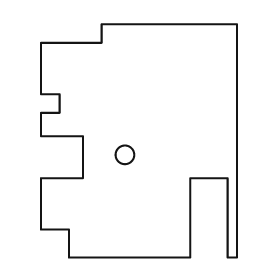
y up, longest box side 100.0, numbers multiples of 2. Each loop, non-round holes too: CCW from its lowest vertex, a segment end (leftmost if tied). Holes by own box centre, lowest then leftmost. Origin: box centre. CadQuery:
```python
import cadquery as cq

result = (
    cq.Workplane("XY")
    .moveTo(-30.0, -50.0)
    .lineTo(22.0, -50.0)
    .lineTo(22.0, -16.0)
    .lineTo(38.0, -16.0)
    .lineTo(38.0, -50.0)
    .lineTo(42.0, -50.0)
    .lineTo(42.0, 50.0)
    .lineTo(-16.0, 50.0)
    .lineTo(-16.0, 42.0)
    .lineTo(-42.0, 42.0)
    .lineTo(-42.0, 20.0)
    .lineTo(-34.0, 20.0)
    .lineTo(-34.0, 12.0)
    .lineTo(-42.0, 12.0)
    .lineTo(-42.0, 2.0)
    .lineTo(-24.0, 2.0)
    .lineTo(-24.0, -16.0)
    .lineTo(-42.0, -16.0)
    .lineTo(-42.0, -38.0)
    .lineTo(-30.0, -38.0)
    .close()
    .moveTo(-6.0, -6.0)
    .circle(4.0)
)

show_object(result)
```